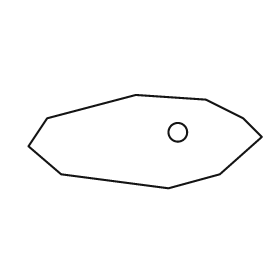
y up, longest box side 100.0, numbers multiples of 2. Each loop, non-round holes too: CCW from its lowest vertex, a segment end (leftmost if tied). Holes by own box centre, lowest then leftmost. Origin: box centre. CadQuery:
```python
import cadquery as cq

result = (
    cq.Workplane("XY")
    .moveTo(10.0, -20.0)
    .lineTo(32.0, -14.0)
    .lineTo(50.0, 2.0)
    .lineTo(42.0, 10.0)
    .lineTo(26.0, 18.0)
    .lineTo(-4.0, 20.0)
    .lineTo(-42.0, 10.0)
    .lineTo(-50.0, -2.0)
    .lineTo(-36.0, -14.0)
    .close()
    .moveTo(14.0, 4.0)
    .circle(4.0)
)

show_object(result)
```